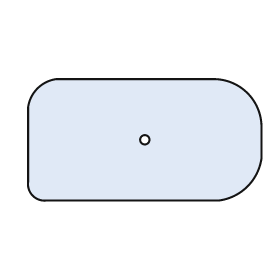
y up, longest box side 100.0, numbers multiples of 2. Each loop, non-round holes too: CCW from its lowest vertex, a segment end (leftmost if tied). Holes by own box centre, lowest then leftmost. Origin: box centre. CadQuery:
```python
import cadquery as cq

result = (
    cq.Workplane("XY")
    .moveTo(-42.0, -26.0)
    .lineTo(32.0, -26.0)
    .threePointArc((44.0, -20.0), (50.0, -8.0))
    .lineTo(50.0, 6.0)
    .threePointArc((44.0, 20.0), (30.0, 26.0))
    .lineTo(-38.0, 26.0)
    .threePointArc((-46.0, 22.0), (-50.0, 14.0))
    .lineTo(-50.0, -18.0)
    .threePointArc((-48.0, -24.0), (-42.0, -26.0))
    .close()
    .moveTo(0.0, 0.0)
    .circle(2.0)
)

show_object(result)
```